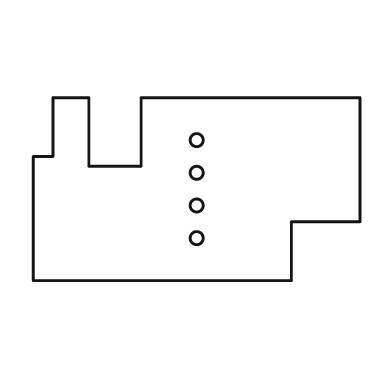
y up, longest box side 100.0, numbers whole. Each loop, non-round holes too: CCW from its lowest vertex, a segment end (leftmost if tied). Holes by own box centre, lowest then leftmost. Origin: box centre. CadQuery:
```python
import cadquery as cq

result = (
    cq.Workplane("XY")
    .moveTo(-50.0, -28.0)
    .lineTo(29.0, -28.0)
    .lineTo(29.0, -10.0)
    .lineTo(50.0, -10.0)
    .lineTo(50.0, 28.0)
    .lineTo(-17.0, 28.0)
    .lineTo(-17.0, 7.0)
    .lineTo(-33.0, 7.0)
    .lineTo(-33.0, 28.0)
    .lineTo(-44.0, 28.0)
    .lineTo(-44.0, 10.0)
    .lineTo(-50.0, 10.0)
    .close()
    .moveTo(0.0, -15.0)
    .circle(2.0)
    .moveTo(0.0, -5.0)
    .circle(2.0)
    .moveTo(0.0, 5.0)
    .circle(2.0)
    .moveTo(0.0, 15.0)
    .circle(2.0)
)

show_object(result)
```